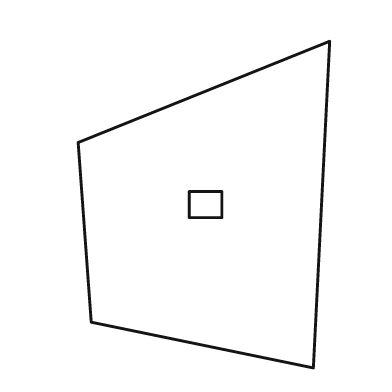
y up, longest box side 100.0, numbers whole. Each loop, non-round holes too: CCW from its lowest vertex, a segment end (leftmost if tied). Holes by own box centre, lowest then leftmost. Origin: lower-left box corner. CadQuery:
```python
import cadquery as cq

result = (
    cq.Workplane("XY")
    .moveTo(72.0, 0.0)
    .lineTo(77.0, 100.0)
    .lineTo(0.0, 69.0)
    .lineTo(4.0, 14.0)
    .close()
    .moveTo(34.0, 46.0)
    .lineTo(44.0, 46.0)
    .lineTo(44.0, 54.0)
    .lineTo(34.0, 54.0)
    .close()
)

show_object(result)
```